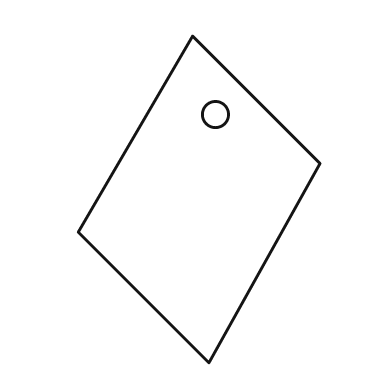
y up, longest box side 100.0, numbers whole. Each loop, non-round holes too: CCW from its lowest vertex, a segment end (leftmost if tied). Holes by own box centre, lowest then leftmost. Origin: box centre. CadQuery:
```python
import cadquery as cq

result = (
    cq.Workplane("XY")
    .moveTo(3.0, -50.0)
    .lineTo(37.0, 11.0)
    .lineTo(-2.0, 50.0)
    .lineTo(-37.0, -10.0)
    .close()
    .moveTo(5.0, 26.0)
    .circle(4.0)
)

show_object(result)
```